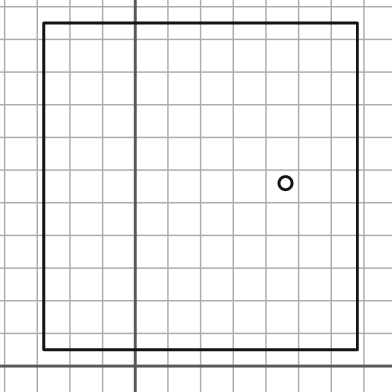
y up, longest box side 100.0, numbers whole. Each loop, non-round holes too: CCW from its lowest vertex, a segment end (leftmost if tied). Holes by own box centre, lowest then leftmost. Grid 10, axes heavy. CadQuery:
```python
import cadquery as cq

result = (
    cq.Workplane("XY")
    .moveTo(-28.0, 5.0)
    .lineTo(68.0, 5.0)
    .lineTo(68.0, 105.0)
    .lineTo(-28.0, 105.0)
    .close()
    .moveTo(46.0, 56.0)
    .circle(2.0)
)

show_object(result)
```